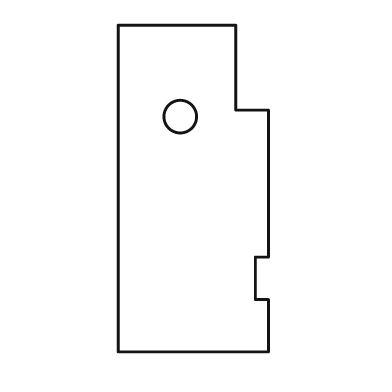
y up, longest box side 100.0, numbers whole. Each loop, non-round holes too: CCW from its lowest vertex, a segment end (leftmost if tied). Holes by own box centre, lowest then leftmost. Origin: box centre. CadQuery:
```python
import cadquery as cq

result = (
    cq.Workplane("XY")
    .moveTo(-23.0, -50.0)
    .lineTo(23.0, -50.0)
    .lineTo(23.0, -34.0)
    .lineTo(19.0, -34.0)
    .lineTo(19.0, -21.0)
    .lineTo(23.0, -21.0)
    .lineTo(23.0, 24.0)
    .lineTo(13.0, 24.0)
    .lineTo(13.0, 50.0)
    .lineTo(-23.0, 50.0)
    .close()
    .moveTo(-4.0, 22.0)
    .circle(5.0)
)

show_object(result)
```